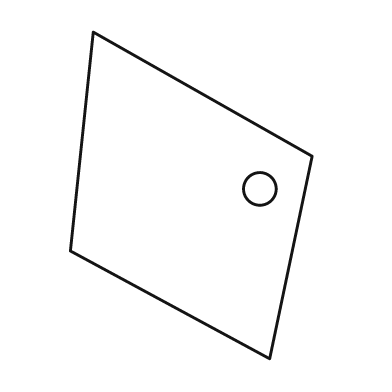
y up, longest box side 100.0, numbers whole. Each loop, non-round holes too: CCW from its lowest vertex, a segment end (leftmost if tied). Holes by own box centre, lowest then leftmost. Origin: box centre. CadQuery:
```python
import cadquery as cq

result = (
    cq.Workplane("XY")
    .moveTo(24.0, -50.0)
    .lineTo(37.0, 12.0)
    .lineTo(-30.0, 50.0)
    .lineTo(-37.0, -17.0)
    .close()
    .moveTo(21.0, 2.0)
    .circle(5.0)
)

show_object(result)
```